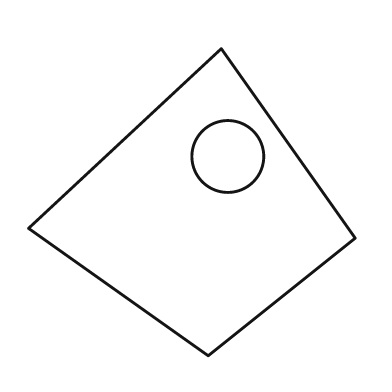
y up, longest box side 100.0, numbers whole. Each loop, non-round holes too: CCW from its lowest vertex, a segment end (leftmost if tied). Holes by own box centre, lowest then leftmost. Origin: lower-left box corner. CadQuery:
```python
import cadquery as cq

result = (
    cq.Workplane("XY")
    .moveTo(55.0, 0.0)
    .lineTo(100.0, 36.0)
    .lineTo(59.0, 94.0)
    .lineTo(0.0, 39.0)
    .close()
    .moveTo(61.0, 61.0)
    .circle(11.0)
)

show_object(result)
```